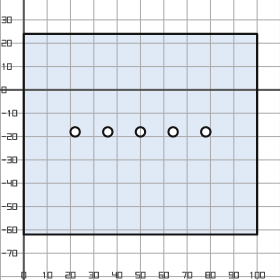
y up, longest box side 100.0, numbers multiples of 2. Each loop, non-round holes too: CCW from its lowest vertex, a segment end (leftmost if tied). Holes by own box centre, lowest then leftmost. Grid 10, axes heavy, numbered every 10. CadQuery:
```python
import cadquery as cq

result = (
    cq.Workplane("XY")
    .moveTo(0.0, -62.0)
    .lineTo(100.0, -62.0)
    .lineTo(100.0, 24.0)
    .lineTo(0.0, 24.0)
    .close()
    .moveTo(22.0, -18.0)
    .circle(2.0)
    .moveTo(36.0, -18.0)
    .circle(2.0)
    .moveTo(50.0, -18.0)
    .circle(2.0)
    .moveTo(64.0, -18.0)
    .circle(2.0)
    .moveTo(78.0, -18.0)
    .circle(2.0)
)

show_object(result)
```